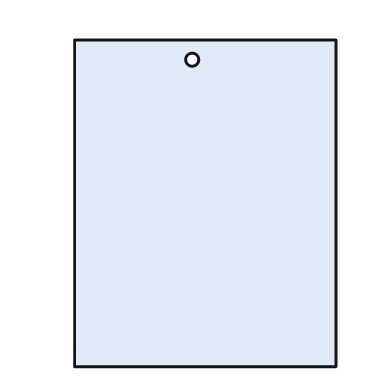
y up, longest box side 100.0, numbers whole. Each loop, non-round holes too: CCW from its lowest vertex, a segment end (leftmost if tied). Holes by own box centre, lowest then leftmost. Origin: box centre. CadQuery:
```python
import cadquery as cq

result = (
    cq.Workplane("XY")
    .moveTo(-40.0, -50.0)
    .lineTo(40.0, -50.0)
    .lineTo(40.0, 50.0)
    .lineTo(-40.0, 50.0)
    .close()
    .moveTo(-4.0, 44.0)
    .circle(2.0)
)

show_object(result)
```